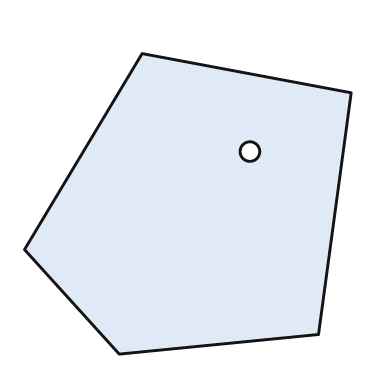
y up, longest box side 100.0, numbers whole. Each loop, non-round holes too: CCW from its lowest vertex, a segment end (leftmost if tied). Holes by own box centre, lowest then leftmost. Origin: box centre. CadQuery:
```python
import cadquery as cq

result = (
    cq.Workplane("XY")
    .moveTo(-21.0, -46.0)
    .lineTo(40.0, -40.0)
    .lineTo(50.0, 34.0)
    .lineTo(-14.0, 46.0)
    .lineTo(-50.0, -14.0)
    .close()
    .moveTo(19.0, 16.0)
    .circle(3.0)
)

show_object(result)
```